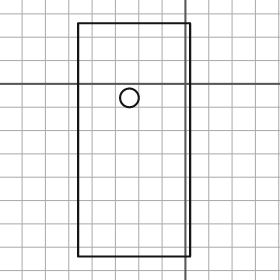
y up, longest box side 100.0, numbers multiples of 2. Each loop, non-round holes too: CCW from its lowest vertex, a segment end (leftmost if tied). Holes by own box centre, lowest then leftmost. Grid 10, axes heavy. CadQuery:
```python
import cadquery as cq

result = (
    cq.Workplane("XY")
    .moveTo(-46.0, -74.0)
    .lineTo(2.0, -74.0)
    .lineTo(2.0, 26.0)
    .lineTo(-46.0, 26.0)
    .close()
    .moveTo(-24.0, -6.0)
    .circle(4.0)
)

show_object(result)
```